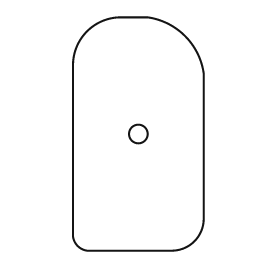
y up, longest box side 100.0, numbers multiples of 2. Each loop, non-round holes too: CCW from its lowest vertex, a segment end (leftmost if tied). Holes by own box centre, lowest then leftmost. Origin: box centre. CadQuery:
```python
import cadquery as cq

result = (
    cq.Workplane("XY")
    .moveTo(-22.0, -50.0)
    .lineTo(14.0, -50.0)
    .threePointArc((24.0, -46.0), (28.0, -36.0))
    .lineTo(28.0, 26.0)
    .threePointArc((20.0, 42.0), (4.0, 50.0))
    .lineTo(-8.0, 50.0)
    .threePointArc((-22.0, 44.0), (-28.0, 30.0))
    .lineTo(-28.0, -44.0)
    .threePointArc((-26.0, -48.0), (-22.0, -50.0))
    .close()
    .moveTo(0.0, 0.0)
    .circle(4.0)
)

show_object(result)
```